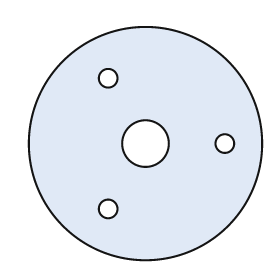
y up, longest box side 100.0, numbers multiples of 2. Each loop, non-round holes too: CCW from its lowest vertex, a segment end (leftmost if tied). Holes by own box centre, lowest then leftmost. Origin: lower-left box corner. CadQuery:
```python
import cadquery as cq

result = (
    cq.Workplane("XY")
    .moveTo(50.0, 50.0)
    .circle(50.0)
    .moveTo(34.0, 22.0)
    .circle(4.0)
    .moveTo(50.0, 50.0)
    .circle(10.0)
    .moveTo(84.0, 50.0)
    .circle(4.0)
    .moveTo(34.0, 78.0)
    .circle(4.0)
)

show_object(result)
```